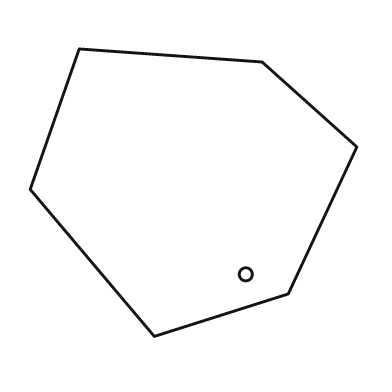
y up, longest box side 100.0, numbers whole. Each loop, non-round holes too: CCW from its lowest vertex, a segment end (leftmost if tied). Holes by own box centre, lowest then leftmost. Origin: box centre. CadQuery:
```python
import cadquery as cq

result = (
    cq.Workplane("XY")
    .moveTo(-12.0, -44.0)
    .lineTo(29.0, -31.0)
    .lineTo(50.0, 14.0)
    .lineTo(21.0, 40.0)
    .lineTo(-35.0, 44.0)
    .lineTo(-50.0, 1.0)
    .close()
    .moveTo(16.0, -25.0)
    .circle(2.0)
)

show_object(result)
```